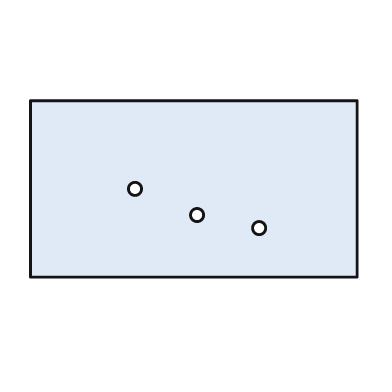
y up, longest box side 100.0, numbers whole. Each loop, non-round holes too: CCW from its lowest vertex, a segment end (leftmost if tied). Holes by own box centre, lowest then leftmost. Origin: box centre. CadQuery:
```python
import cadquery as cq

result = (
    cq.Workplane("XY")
    .moveTo(-50.0, -27.0)
    .lineTo(50.0, -27.0)
    .lineTo(50.0, 27.0)
    .lineTo(-50.0, 27.0)
    .close()
    .moveTo(20.0, -12.0)
    .circle(2.0)
    .moveTo(1.0, -8.0)
    .circle(2.0)
    .moveTo(-18.0, 0.0)
    .circle(2.0)
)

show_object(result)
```